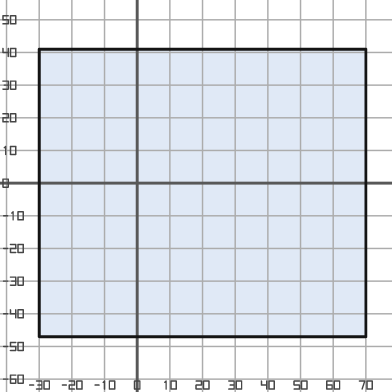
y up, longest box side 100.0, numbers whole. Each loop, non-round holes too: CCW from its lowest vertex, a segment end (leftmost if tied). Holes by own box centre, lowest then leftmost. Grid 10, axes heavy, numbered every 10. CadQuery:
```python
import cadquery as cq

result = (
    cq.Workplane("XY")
    .moveTo(-30.0, -47.0)
    .lineTo(70.0, -47.0)
    .lineTo(70.0, 41.0)
    .lineTo(-30.0, 41.0)
    .close()
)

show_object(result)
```